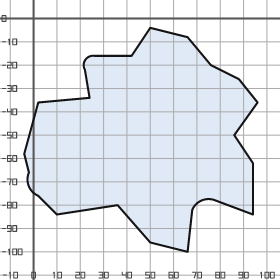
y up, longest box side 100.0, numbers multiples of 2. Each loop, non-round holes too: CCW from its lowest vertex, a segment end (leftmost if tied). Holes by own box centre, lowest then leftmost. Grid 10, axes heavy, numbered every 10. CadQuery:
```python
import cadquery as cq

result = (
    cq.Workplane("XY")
    .moveTo(66.0, -100.0)
    .lineTo(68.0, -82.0)
    .threePointArc((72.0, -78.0), (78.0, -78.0))
    .lineTo(94.0, -84.0)
    .lineTo(94.0, -62.0)
    .lineTo(86.0, -50.0)
    .lineTo(96.0, -36.0)
    .lineTo(88.0, -26.0)
    .lineTo(76.0, -20.0)
    .lineTo(66.0, -8.0)
    .lineTo(50.0, -4.0)
    .lineTo(42.0, -16.0)
    .lineTo(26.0, -16.0)
    .threePointArc((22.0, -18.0), (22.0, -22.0))
    .lineTo(24.0, -34.0)
    .lineTo(2.0, -36.0)
    .lineTo(-4.0, -58.0)
    .lineTo(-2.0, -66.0)
    .threePointArc((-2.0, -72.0), (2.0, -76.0))
    .lineTo(10.0, -84.0)
    .lineTo(36.0, -80.0)
    .lineTo(50.0, -96.0)
    .close()
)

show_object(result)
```